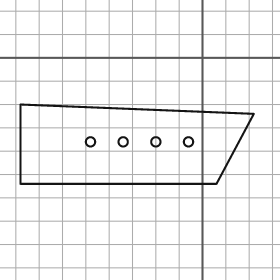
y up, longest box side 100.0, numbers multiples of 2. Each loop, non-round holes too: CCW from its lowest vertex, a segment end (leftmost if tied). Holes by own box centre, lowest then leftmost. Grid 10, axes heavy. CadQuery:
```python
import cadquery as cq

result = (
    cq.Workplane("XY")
    .moveTo(-78.0, -54.0)
    .lineTo(6.0, -54.0)
    .lineTo(22.0, -24.0)
    .lineTo(-78.0, -20.0)
    .close()
    .moveTo(-48.0, -36.0)
    .circle(2.0)
    .moveTo(-34.0, -36.0)
    .circle(2.0)
    .moveTo(-20.0, -36.0)
    .circle(2.0)
    .moveTo(-6.0, -36.0)
    .circle(2.0)
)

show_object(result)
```